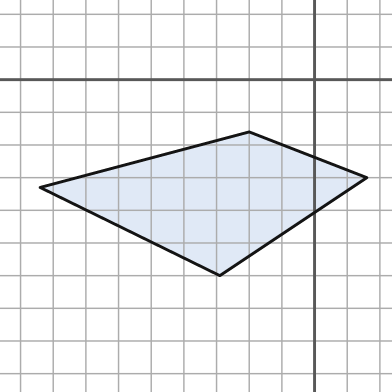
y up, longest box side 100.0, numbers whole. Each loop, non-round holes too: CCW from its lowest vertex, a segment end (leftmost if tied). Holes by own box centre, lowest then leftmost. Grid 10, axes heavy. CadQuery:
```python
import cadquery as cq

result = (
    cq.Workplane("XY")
    .moveTo(-29.0, -60.0)
    .lineTo(16.0, -30.0)
    .lineTo(-20.0, -16.0)
    .lineTo(-84.0, -33.0)
    .close()
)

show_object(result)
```